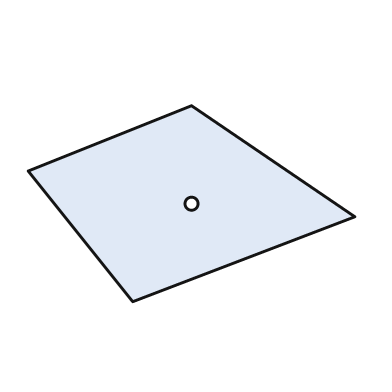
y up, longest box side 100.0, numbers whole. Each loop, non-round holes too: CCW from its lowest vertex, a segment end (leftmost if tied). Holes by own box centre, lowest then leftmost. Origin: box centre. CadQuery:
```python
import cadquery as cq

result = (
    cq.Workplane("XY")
    .moveTo(-18.0, -30.0)
    .lineTo(50.0, -4.0)
    .lineTo(0.0, 30.0)
    .lineTo(-50.0, 10.0)
    .close()
    .moveTo(0.0, 0.0)
    .circle(2.0)
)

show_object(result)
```